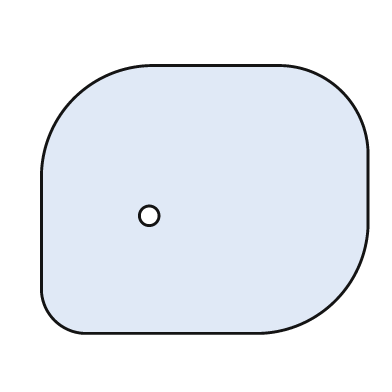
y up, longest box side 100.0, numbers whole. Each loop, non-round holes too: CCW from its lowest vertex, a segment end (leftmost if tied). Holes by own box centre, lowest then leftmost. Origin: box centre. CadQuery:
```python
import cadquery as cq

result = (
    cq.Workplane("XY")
    .moveTo(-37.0, -41.0)
    .lineTo(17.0, -41.0)
    .threePointArc((40.0, -31.0), (50.0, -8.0))
    .lineTo(50.0, 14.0)
    .threePointArc((42.0, 33.0), (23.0, 41.0))
    .lineTo(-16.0, 41.0)
    .threePointArc((-40.0, 31.0), (-50.0, 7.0))
    .lineTo(-50.0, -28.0)
    .threePointArc((-46.0, -37.0), (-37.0, -41.0))
    .close()
    .moveTo(-17.0, -5.0)
    .circle(3.0)
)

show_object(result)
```